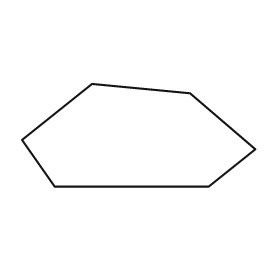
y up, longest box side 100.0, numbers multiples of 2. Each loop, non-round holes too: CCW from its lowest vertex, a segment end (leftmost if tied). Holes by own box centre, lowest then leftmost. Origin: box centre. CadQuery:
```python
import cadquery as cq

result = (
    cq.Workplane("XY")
    .moveTo(-36.0, -22.0)
    .lineTo(30.0, -22.0)
    .lineTo(50.0, -6.0)
    .lineTo(22.0, 18.0)
    .lineTo(-20.0, 22.0)
    .lineTo(-50.0, -2.0)
    .close()
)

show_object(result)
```